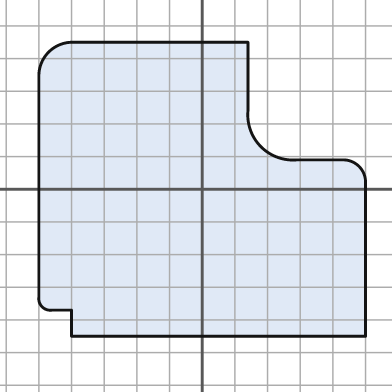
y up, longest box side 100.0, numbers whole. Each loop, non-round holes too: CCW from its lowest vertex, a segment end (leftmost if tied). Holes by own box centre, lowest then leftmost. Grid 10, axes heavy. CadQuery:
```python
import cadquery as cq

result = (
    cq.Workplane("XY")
    .moveTo(-40.0, -45.0)
    .lineTo(50.0, -45.0)
    .lineTo(50.0, 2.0)
    .threePointArc((48.0, 7.0), (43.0, 9.0))
    .lineTo(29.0, 9.0)
    .threePointArc((18.0, 13.0), (14.0, 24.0))
    .lineTo(14.0, 45.0)
    .lineTo(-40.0, 45.0)
    .threePointArc((-47.0, 42.0), (-50.0, 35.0))
    .lineTo(-50.0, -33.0)
    .threePointArc((-49.0, -36.0), (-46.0, -37.0))
    .lineTo(-40.0, -37.0)
    .close()
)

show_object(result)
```